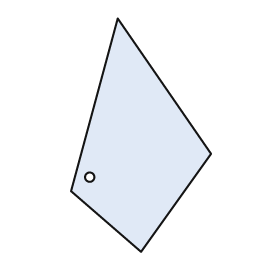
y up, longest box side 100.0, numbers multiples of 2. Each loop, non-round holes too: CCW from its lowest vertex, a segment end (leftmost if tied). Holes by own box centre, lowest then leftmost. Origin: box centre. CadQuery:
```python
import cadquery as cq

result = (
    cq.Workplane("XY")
    .moveTo(0.0, -50.0)
    .lineTo(30.0, -8.0)
    .lineTo(-10.0, 50.0)
    .lineTo(-30.0, -24.0)
    .close()
    .moveTo(-22.0, -18.0)
    .circle(2.0)
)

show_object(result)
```